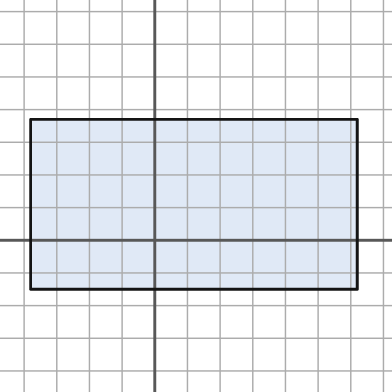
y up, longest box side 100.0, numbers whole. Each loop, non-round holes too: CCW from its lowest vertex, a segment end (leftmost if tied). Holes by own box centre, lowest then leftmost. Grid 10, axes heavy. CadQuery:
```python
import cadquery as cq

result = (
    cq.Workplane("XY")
    .moveTo(-38.0, -15.0)
    .lineTo(62.0, -15.0)
    .lineTo(62.0, 37.0)
    .lineTo(-38.0, 37.0)
    .close()
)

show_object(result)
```